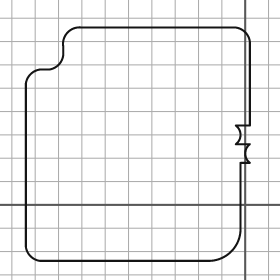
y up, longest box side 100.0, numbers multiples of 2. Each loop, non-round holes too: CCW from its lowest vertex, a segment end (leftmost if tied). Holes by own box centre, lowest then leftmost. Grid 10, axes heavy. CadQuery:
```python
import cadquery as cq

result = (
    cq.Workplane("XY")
    .moveTo(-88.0, -24.0)
    .lineTo(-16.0, -24.0)
    .threePointArc((-6.0, -20.0), (-2.0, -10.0))
    .lineTo(-2.0, 18.0)
    .lineTo(2.0, 18.0)
    .threePointArc((0.0, 22.0), (2.0, 26.0))
    .lineTo(-4.0, 26.0)
    .threePointArc((-2.0, 30.0), (-4.0, 34.0))
    .lineTo(2.0, 34.0)
    .lineTo(2.0, 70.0)
    .threePointArc((0.0, 74.0), (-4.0, 76.0))
    .lineTo(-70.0, 76.0)
    .threePointArc((-76.0, 74.0), (-78.0, 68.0))
    .lineTo(-78.0, 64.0)
    .threePointArc((-80.0, 60.0), (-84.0, 58.0))
    .lineTo(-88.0, 58.0)
    .threePointArc((-92.0, 56.0), (-94.0, 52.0))
    .lineTo(-94.0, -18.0)
    .threePointArc((-92.0, -22.0), (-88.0, -24.0))
    .close()
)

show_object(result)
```